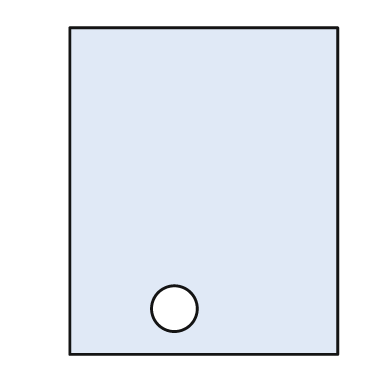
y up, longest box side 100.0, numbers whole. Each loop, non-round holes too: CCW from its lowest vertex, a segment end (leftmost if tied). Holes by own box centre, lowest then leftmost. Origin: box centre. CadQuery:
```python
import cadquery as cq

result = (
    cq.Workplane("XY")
    .moveTo(-41.0, -50.0)
    .lineTo(41.0, -50.0)
    .lineTo(41.0, 50.0)
    .lineTo(-41.0, 50.0)
    .close()
    .moveTo(-9.0, -36.0)
    .circle(7.0)
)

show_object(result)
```